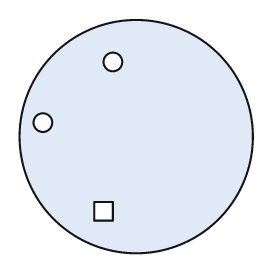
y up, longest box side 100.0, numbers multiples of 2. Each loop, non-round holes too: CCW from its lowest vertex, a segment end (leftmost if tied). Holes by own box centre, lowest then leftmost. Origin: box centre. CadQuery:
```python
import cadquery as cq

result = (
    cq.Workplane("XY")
    .moveTo(0.0, 0.0)
    .circle(50.0)
    .moveTo(-18.0, -36.0)
    .lineTo(-10.0, -36.0)
    .lineTo(-10.0, -28.0)
    .lineTo(-18.0, -28.0)
    .close()
    .moveTo(-40.0, 6.0)
    .circle(4.0)
    .moveTo(-10.0, 32.0)
    .circle(4.0)
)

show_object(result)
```